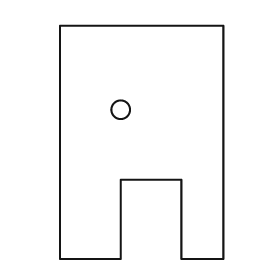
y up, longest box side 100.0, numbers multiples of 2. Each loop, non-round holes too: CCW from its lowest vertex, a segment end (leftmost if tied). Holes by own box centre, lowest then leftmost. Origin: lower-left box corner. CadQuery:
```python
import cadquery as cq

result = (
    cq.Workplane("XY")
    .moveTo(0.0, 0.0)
    .lineTo(26.0, 0.0)
    .lineTo(26.0, 34.0)
    .lineTo(52.0, 34.0)
    .lineTo(52.0, 0.0)
    .lineTo(70.0, 0.0)
    .lineTo(70.0, 100.0)
    .lineTo(0.0, 100.0)
    .close()
    .moveTo(26.0, 64.0)
    .circle(4.0)
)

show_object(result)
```